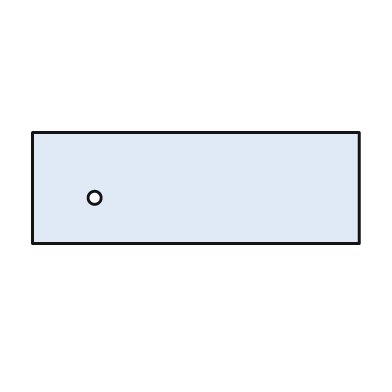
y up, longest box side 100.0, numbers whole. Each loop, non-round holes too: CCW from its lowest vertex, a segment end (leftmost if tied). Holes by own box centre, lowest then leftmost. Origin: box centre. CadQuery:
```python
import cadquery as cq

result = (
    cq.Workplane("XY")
    .moveTo(-50.0, -17.0)
    .lineTo(50.0, -17.0)
    .lineTo(50.0, 17.0)
    .lineTo(-50.0, 17.0)
    .close()
    .moveTo(-31.0, -3.0)
    .circle(2.0)
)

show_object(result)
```